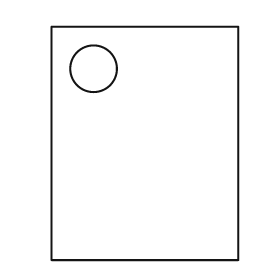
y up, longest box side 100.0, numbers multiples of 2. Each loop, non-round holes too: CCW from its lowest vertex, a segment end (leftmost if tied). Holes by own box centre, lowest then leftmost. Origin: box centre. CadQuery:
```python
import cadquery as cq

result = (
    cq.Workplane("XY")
    .moveTo(-40.0, -50.0)
    .lineTo(40.0, -50.0)
    .lineTo(40.0, 50.0)
    .lineTo(-40.0, 50.0)
    .close()
    .moveTo(-22.0, 32.0)
    .circle(10.0)
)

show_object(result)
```